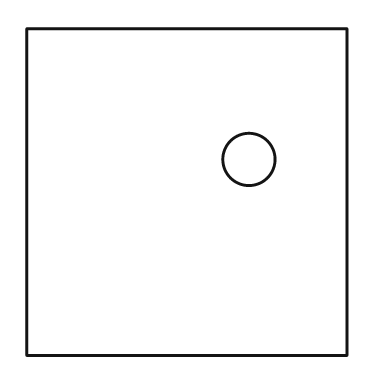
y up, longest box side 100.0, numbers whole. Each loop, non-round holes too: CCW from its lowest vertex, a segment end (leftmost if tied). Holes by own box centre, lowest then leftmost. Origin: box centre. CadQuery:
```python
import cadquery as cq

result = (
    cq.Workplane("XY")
    .moveTo(-49.0, -50.0)
    .lineTo(49.0, -50.0)
    .lineTo(49.0, 50.0)
    .lineTo(-49.0, 50.0)
    .close()
    .moveTo(19.0, 10.0)
    .circle(8.0)
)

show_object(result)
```